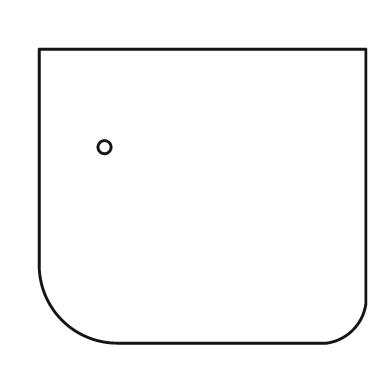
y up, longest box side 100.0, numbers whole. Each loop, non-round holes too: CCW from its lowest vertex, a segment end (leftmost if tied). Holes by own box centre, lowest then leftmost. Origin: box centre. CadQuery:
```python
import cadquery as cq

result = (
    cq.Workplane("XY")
    .moveTo(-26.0, -45.0)
    .lineTo(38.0, -45.0)
    .threePointArc((46.0, -41.0), (50.0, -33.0))
    .lineTo(50.0, 45.0)
    .lineTo(-50.0, 45.0)
    .lineTo(-50.0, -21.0)
    .threePointArc((-43.0, -38.0), (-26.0, -45.0))
    .close()
    .moveTo(-30.0, 15.0)
    .circle(2.0)
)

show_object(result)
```